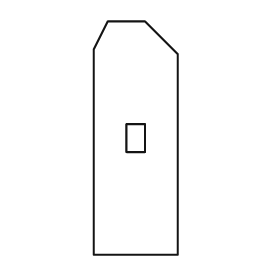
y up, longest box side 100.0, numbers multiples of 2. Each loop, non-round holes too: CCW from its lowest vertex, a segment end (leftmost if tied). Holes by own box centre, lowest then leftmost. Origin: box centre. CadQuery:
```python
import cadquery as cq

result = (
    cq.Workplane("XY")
    .moveTo(-18.0, -50.0)
    .lineTo(18.0, -50.0)
    .lineTo(18.0, 36.0)
    .lineTo(4.0, 50.0)
    .lineTo(-12.0, 50.0)
    .lineTo(-18.0, 38.0)
    .close()
    .moveTo(-4.0, -6.0)
    .lineTo(4.0, -6.0)
    .lineTo(4.0, 6.0)
    .lineTo(-4.0, 6.0)
    .close()
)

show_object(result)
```